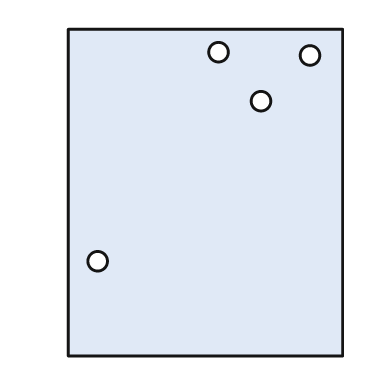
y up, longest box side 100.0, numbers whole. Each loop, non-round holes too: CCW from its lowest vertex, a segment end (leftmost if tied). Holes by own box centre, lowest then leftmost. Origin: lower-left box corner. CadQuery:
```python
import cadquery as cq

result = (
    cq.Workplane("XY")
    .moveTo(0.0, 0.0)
    .lineTo(84.0, 0.0)
    .lineTo(84.0, 100.0)
    .lineTo(0.0, 100.0)
    .close()
    .moveTo(9.0, 29.0)
    .circle(3.0)
    .moveTo(59.0, 78.0)
    .circle(3.0)
    .moveTo(74.0, 92.0)
    .circle(3.0)
    .moveTo(46.0, 93.0)
    .circle(3.0)
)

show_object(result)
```